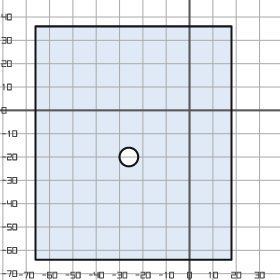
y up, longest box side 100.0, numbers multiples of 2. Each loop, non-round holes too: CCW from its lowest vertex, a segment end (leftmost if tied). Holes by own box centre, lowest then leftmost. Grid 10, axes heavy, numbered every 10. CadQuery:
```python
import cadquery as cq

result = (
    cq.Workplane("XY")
    .moveTo(-66.0, -64.0)
    .lineTo(18.0, -64.0)
    .lineTo(18.0, 36.0)
    .lineTo(-66.0, 36.0)
    .close()
    .moveTo(-26.0, -20.0)
    .circle(4.0)
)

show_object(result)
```